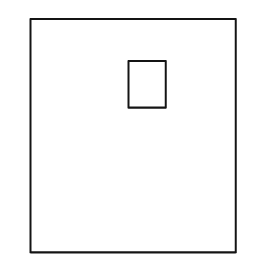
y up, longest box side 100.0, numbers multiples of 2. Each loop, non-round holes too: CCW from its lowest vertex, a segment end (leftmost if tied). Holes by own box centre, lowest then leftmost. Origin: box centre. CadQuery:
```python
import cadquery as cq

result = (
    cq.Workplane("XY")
    .moveTo(-44.0, -50.0)
    .lineTo(44.0, -50.0)
    .lineTo(44.0, 50.0)
    .lineTo(-44.0, 50.0)
    .close()
    .moveTo(-2.0, 12.0)
    .lineTo(14.0, 12.0)
    .lineTo(14.0, 32.0)
    .lineTo(-2.0, 32.0)
    .close()
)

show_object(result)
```